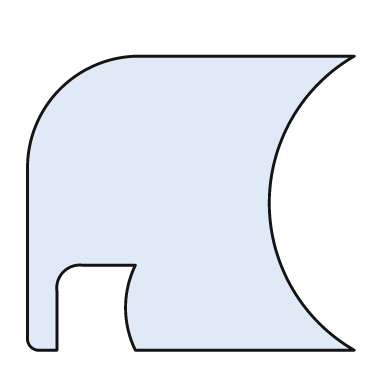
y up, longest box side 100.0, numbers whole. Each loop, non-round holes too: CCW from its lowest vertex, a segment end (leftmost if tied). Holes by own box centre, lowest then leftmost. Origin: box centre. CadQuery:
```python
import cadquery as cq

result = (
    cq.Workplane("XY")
    .moveTo(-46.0, -45.0)
    .lineTo(-41.0, -45.0)
    .lineTo(-41.0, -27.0)
    .threePointArc((-39.0, -21.0), (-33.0, -19.0))
    .lineTo(-17.0, -19.0)
    .threePointArc((-20.0, -32.0), (-17.0, -45.0))
    .lineTo(50.0, -45.0)
    .threePointArc((24.0, 0.0), (50.0, 45.0))
    .lineTo(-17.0, 45.0)
    .threePointArc((-40.0, 35.0), (-50.0, 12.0))
    .lineTo(-50.0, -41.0)
    .threePointArc((-49.0, -44.0), (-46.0, -45.0))
    .close()
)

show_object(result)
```